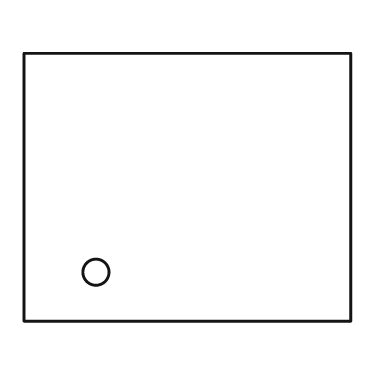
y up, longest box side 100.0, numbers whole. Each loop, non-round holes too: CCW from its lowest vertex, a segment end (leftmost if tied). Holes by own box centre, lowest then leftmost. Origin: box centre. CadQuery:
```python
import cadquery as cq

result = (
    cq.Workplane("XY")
    .moveTo(-50.0, -41.0)
    .lineTo(50.0, -41.0)
    .lineTo(50.0, 41.0)
    .lineTo(-50.0, 41.0)
    .close()
    .moveTo(-28.0, -26.0)
    .circle(4.0)
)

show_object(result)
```